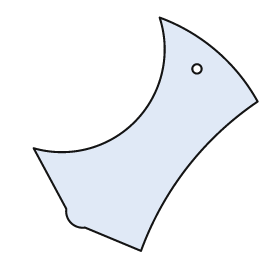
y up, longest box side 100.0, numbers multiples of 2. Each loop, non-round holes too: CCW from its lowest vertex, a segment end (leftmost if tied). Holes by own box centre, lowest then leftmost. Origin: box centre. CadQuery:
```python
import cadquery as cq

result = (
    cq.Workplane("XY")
    .moveTo(-2.0, -50.0)
    .threePointArc((18.0, -14.0), (48.0, 14.0))
    .threePointArc((30.0, 36.0), (6.0, 50.0))
    .threePointArc((-4.0, 6.0), (-48.0, -6.0))
    .lineTo(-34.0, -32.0)
    .threePointArc((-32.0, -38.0), (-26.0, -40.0))
    .close()
    .moveTo(22.0, 28.0)
    .circle(2.0)
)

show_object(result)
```